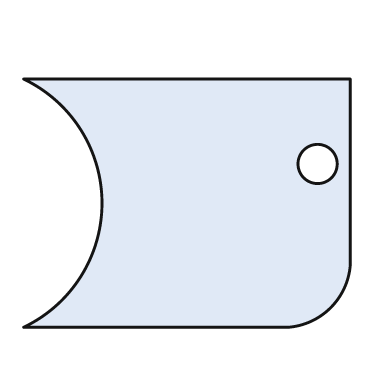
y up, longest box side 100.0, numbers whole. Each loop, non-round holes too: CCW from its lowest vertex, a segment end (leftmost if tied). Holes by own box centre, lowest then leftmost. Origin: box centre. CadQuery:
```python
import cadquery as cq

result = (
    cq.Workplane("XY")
    .moveTo(-50.0, -38.0)
    .lineTo(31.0, -38.0)
    .threePointArc((44.0, -32.0), (50.0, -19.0))
    .lineTo(50.0, 38.0)
    .lineTo(-50.0, 38.0)
    .threePointArc((-26.0, 0.0), (-50.0, -38.0))
    .close()
    .moveTo(40.0, 12.0)
    .circle(6.0)
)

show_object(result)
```